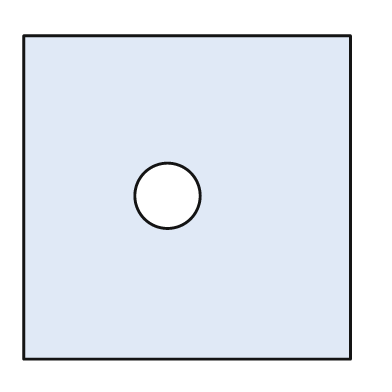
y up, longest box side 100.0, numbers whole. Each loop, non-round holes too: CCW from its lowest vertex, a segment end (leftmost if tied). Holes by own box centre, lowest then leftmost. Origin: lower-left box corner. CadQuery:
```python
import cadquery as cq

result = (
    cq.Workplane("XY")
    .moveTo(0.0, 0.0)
    .lineTo(100.0, 0.0)
    .lineTo(100.0, 99.0)
    .lineTo(0.0, 99.0)
    .close()
    .moveTo(44.0, 50.0)
    .circle(10.0)
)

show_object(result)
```